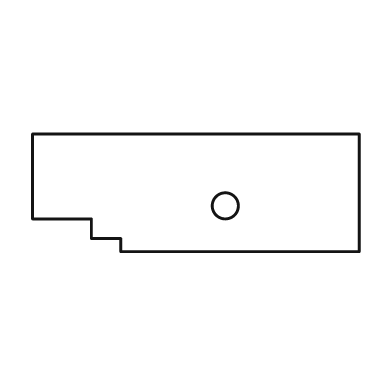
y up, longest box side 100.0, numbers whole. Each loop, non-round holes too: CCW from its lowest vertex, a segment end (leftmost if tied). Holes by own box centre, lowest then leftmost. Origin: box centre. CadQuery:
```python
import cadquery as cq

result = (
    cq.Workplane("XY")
    .moveTo(-23.0, -18.0)
    .lineTo(50.0, -18.0)
    .lineTo(50.0, 18.0)
    .lineTo(-50.0, 18.0)
    .lineTo(-50.0, -8.0)
    .lineTo(-32.0, -8.0)
    .lineTo(-32.0, -14.0)
    .lineTo(-23.0, -14.0)
    .close()
    .moveTo(9.0, -4.0)
    .circle(4.0)
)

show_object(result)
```